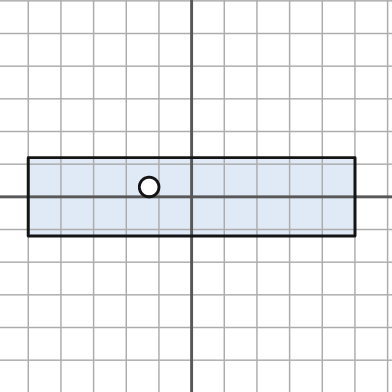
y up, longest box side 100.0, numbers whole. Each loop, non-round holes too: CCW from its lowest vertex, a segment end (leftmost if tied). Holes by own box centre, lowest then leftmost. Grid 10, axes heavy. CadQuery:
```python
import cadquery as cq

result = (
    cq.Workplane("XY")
    .moveTo(-50.0, -12.0)
    .lineTo(50.0, -12.0)
    .lineTo(50.0, 12.0)
    .lineTo(-50.0, 12.0)
    .close()
    .moveTo(-13.0, 3.0)
    .circle(3.0)
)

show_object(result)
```